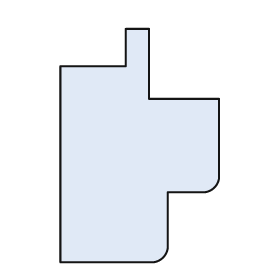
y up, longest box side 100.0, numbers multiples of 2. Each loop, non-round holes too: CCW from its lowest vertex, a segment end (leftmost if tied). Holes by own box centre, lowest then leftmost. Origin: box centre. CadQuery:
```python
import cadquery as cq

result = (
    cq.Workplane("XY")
    .moveTo(-34.0, -50.0)
    .lineTo(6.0, -50.0)
    .threePointArc((10.0, -48.0), (12.0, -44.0))
    .lineTo(12.0, -20.0)
    .lineTo(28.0, -20.0)
    .threePointArc((32.0, -18.0), (34.0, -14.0))
    .lineTo(34.0, 20.0)
    .lineTo(4.0, 20.0)
    .lineTo(4.0, 50.0)
    .lineTo(-6.0, 50.0)
    .lineTo(-6.0, 34.0)
    .lineTo(-34.0, 34.0)
    .close()
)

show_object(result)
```